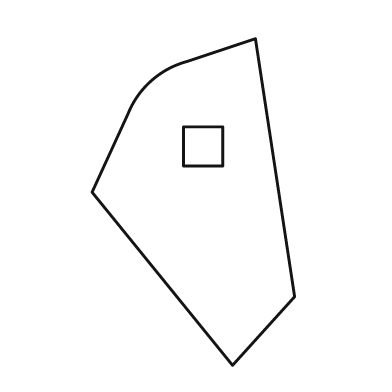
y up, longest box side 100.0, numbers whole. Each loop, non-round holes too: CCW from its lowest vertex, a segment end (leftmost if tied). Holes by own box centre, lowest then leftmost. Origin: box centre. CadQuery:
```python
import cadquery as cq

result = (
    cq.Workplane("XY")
    .moveTo(12.0, -50.0)
    .lineTo(31.0, -29.0)
    .lineTo(19.0, 50.0)
    .lineTo(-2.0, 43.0)
    .threePointArc((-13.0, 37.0), (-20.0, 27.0))
    .lineTo(-31.0, 3.0)
    .close()
    .moveTo(-3.0, 11.0)
    .lineTo(9.0, 11.0)
    .lineTo(9.0, 23.0)
    .lineTo(-3.0, 23.0)
    .close()
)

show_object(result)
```